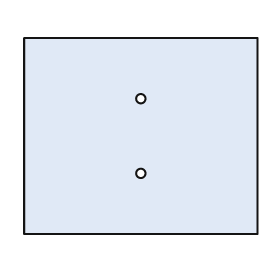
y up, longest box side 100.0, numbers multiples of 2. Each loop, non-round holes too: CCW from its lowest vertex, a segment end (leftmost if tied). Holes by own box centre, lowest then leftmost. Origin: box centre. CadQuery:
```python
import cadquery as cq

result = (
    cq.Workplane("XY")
    .moveTo(-50.0, -42.0)
    .lineTo(50.0, -42.0)
    .lineTo(50.0, 42.0)
    .lineTo(-50.0, 42.0)
    .close()
    .moveTo(0.0, -16.0)
    .circle(2.0)
    .moveTo(0.0, 16.0)
    .circle(2.0)
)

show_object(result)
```